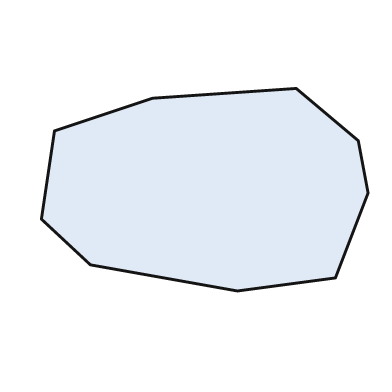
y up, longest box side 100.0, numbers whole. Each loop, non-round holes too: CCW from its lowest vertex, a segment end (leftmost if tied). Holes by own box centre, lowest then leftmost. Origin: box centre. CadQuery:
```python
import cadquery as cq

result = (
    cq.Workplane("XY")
    .moveTo(10.0, -31.0)
    .lineTo(40.0, -27.0)
    .lineTo(50.0, -1.0)
    .lineTo(47.0, 15.0)
    .lineTo(28.0, 31.0)
    .lineTo(-16.0, 28.0)
    .lineTo(-46.0, 18.0)
    .lineTo(-50.0, -9.0)
    .lineTo(-35.0, -23.0)
    .close()
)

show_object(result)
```